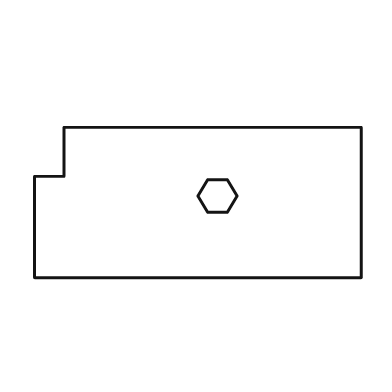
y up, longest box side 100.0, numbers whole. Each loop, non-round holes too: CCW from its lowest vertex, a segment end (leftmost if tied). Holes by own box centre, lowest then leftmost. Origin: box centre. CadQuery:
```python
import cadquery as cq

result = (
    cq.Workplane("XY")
    .moveTo(-50.0, -23.0)
    .lineTo(50.0, -23.0)
    .lineTo(50.0, 23.0)
    .lineTo(-41.0, 23.0)
    .lineTo(-41.0, 8.0)
    .lineTo(-50.0, 8.0)
    .close()
    .moveTo(3.0, -3.0)
    .lineTo(9.0, -3.0)
    .lineTo(12.0, 2.0)
    .lineTo(9.0, 7.0)
    .lineTo(3.0, 7.0)
    .lineTo(0.0, 2.0)
    .close()
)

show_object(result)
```